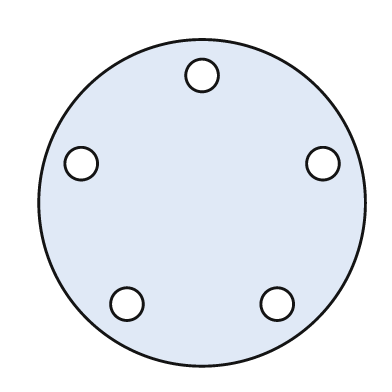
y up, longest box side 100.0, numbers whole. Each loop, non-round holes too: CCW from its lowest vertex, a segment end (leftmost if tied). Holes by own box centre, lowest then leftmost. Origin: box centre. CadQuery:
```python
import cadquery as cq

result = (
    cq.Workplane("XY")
    .moveTo(0.0, 0.0)
    .circle(50.0)
    .moveTo(-23.0, -31.0)
    .circle(5.0)
    .moveTo(23.0, -31.0)
    .circle(5.0)
    .moveTo(-37.0, 12.0)
    .circle(5.0)
    .moveTo(37.0, 12.0)
    .circle(5.0)
    .moveTo(0.0, 39.0)
    .circle(5.0)
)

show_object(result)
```